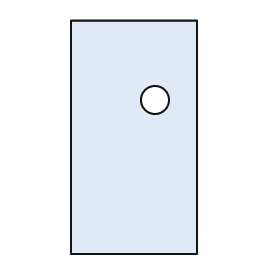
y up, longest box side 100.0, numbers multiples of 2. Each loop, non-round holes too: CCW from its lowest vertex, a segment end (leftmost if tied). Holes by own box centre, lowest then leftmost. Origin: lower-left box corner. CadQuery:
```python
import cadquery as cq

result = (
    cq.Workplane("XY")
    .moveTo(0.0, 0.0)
    .lineTo(54.0, 0.0)
    .lineTo(54.0, 100.0)
    .lineTo(0.0, 100.0)
    .close()
    .moveTo(36.0, 66.0)
    .circle(6.0)
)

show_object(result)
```